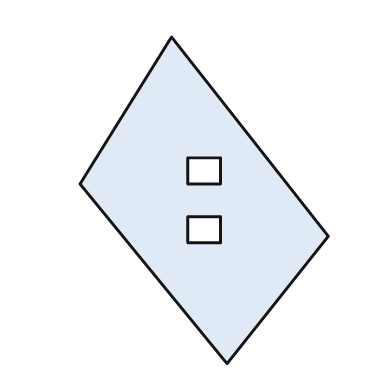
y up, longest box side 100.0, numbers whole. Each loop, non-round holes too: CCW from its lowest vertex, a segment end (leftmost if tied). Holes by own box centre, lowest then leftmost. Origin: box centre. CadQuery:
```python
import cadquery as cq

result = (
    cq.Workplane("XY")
    .moveTo(7.0, -50.0)
    .lineTo(38.0, -11.0)
    .lineTo(-10.0, 50.0)
    .lineTo(-38.0, 5.0)
    .close()
    .moveTo(-5.0, -13.0)
    .lineTo(5.0, -13.0)
    .lineTo(5.0, -5.0)
    .lineTo(-5.0, -5.0)
    .close()
    .moveTo(-5.0, 5.0)
    .lineTo(5.0, 5.0)
    .lineTo(5.0, 13.0)
    .lineTo(-5.0, 13.0)
    .close()
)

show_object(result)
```